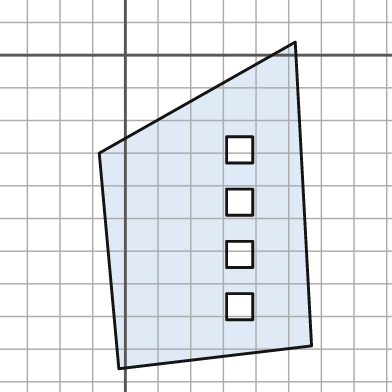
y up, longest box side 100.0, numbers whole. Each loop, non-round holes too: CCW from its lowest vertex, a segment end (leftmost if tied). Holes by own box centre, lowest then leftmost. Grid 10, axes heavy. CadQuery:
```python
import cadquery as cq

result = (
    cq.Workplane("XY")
    .moveTo(-2.0, -96.0)
    .lineTo(57.0, -89.0)
    .lineTo(52.0, 4.0)
    .lineTo(-8.0, -30.0)
    .close()
    .moveTo(31.0, -81.0)
    .lineTo(39.0, -81.0)
    .lineTo(39.0, -73.0)
    .lineTo(31.0, -73.0)
    .close()
    .moveTo(31.0, -65.0)
    .lineTo(39.0, -65.0)
    .lineTo(39.0, -57.0)
    .lineTo(31.0, -57.0)
    .close()
    .moveTo(31.0, -49.0)
    .lineTo(39.0, -49.0)
    .lineTo(39.0, -41.0)
    .lineTo(31.0, -41.0)
    .close()
    .moveTo(31.0, -33.0)
    .lineTo(39.0, -33.0)
    .lineTo(39.0, -25.0)
    .lineTo(31.0, -25.0)
    .close()
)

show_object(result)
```